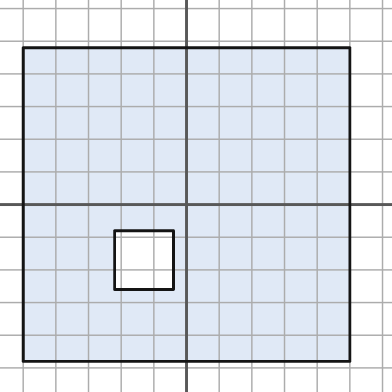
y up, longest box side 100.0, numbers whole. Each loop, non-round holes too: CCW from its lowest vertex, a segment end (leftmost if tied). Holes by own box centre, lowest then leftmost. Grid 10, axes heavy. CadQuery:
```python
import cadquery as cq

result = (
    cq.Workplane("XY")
    .moveTo(-50.0, -48.0)
    .lineTo(50.0, -48.0)
    .lineTo(50.0, 48.0)
    .lineTo(-50.0, 48.0)
    .close()
    .moveTo(-22.0, -26.0)
    .lineTo(-4.0, -26.0)
    .lineTo(-4.0, -8.0)
    .lineTo(-22.0, -8.0)
    .close()
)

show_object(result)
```